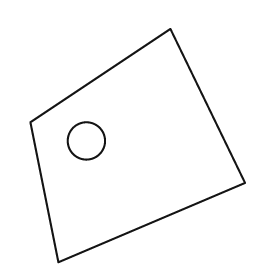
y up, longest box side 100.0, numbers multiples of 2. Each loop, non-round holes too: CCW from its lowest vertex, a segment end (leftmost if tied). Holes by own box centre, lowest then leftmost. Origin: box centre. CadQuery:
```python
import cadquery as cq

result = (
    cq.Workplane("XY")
    .moveTo(-34.0, -50.0)
    .lineTo(46.0, -16.0)
    .lineTo(14.0, 50.0)
    .lineTo(-46.0, 10.0)
    .close()
    .moveTo(-22.0, 2.0)
    .circle(8.0)
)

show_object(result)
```